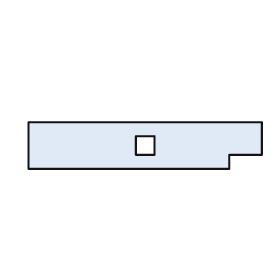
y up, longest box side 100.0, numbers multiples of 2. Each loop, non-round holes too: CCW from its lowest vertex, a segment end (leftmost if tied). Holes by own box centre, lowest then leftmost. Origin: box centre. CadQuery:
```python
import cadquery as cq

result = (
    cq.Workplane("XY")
    .moveTo(-50.0, -10.0)
    .lineTo(36.0, -10.0)
    .lineTo(36.0, -4.0)
    .lineTo(50.0, -4.0)
    .lineTo(50.0, 10.0)
    .lineTo(-50.0, 10.0)
    .close()
    .moveTo(-4.0, -4.0)
    .lineTo(4.0, -4.0)
    .lineTo(4.0, 4.0)
    .lineTo(-4.0, 4.0)
    .close()
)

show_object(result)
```